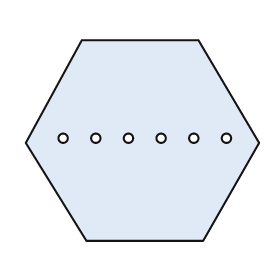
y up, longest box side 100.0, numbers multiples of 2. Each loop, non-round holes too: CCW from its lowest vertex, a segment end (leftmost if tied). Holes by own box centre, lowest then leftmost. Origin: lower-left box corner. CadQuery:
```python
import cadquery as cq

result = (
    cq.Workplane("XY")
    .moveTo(26.0, 0.0)
    .lineTo(76.0, 0.0)
    .lineTo(100.0, 42.0)
    .lineTo(74.0, 86.0)
    .lineTo(24.0, 86.0)
    .lineTo(0.0, 42.0)
    .close()
    .moveTo(16.0, 44.0)
    .circle(2.0)
    .moveTo(30.0, 44.0)
    .circle(2.0)
    .moveTo(44.0, 44.0)
    .circle(2.0)
    .moveTo(58.0, 44.0)
    .circle(2.0)
    .moveTo(72.0, 44.0)
    .circle(2.0)
    .moveTo(86.0, 44.0)
    .circle(2.0)
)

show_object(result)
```